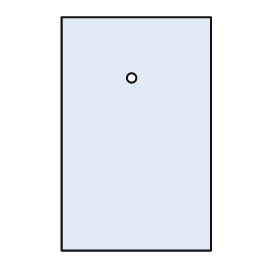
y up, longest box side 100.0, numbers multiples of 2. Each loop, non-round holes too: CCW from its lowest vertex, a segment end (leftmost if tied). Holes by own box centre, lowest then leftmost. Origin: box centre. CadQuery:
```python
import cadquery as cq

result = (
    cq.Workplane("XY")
    .moveTo(-32.0, -50.0)
    .lineTo(32.0, -50.0)
    .lineTo(32.0, 50.0)
    .lineTo(-32.0, 50.0)
    .close()
    .moveTo(-2.0, 24.0)
    .circle(2.0)
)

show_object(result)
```